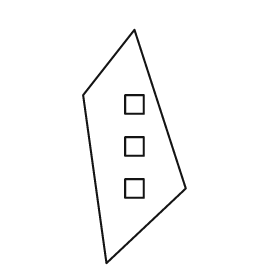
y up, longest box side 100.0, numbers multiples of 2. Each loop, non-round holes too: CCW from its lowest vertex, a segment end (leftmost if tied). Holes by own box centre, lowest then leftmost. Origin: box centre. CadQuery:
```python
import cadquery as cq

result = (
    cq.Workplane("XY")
    .moveTo(-12.0, -50.0)
    .lineTo(22.0, -18.0)
    .lineTo(0.0, 50.0)
    .lineTo(-22.0, 22.0)
    .close()
    .moveTo(-4.0, -22.0)
    .lineTo(4.0, -22.0)
    .lineTo(4.0, -14.0)
    .lineTo(-4.0, -14.0)
    .close()
    .moveTo(-4.0, -4.0)
    .lineTo(4.0, -4.0)
    .lineTo(4.0, 4.0)
    .lineTo(-4.0, 4.0)
    .close()
    .moveTo(-4.0, 14.0)
    .lineTo(4.0, 14.0)
    .lineTo(4.0, 22.0)
    .lineTo(-4.0, 22.0)
    .close()
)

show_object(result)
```